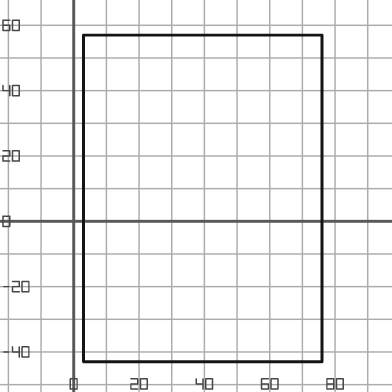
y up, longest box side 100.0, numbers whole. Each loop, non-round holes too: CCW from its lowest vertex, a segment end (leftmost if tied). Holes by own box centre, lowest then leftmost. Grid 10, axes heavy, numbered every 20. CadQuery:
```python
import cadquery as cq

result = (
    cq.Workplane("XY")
    .moveTo(3.0, -43.0)
    .lineTo(76.0, -43.0)
    .lineTo(76.0, 57.0)
    .lineTo(3.0, 57.0)
    .close()
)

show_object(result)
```